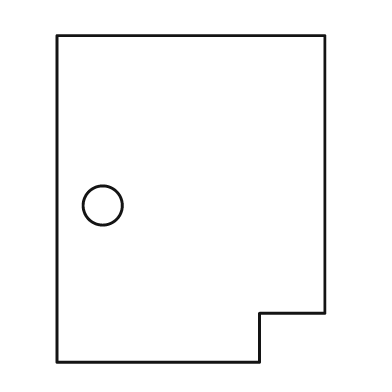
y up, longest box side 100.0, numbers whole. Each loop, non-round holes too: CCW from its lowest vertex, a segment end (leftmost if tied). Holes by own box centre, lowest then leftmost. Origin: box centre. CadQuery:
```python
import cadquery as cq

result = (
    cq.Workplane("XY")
    .moveTo(-41.0, -50.0)
    .lineTo(21.0, -50.0)
    .lineTo(21.0, -35.0)
    .lineTo(41.0, -35.0)
    .lineTo(41.0, 50.0)
    .lineTo(-41.0, 50.0)
    .close()
    .moveTo(-27.0, -2.0)
    .circle(6.0)
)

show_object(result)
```